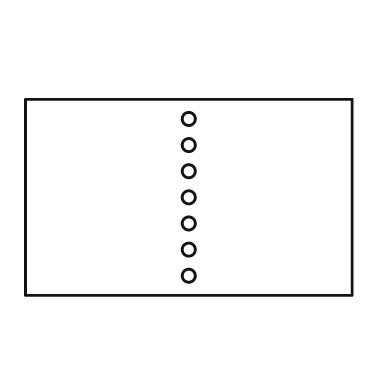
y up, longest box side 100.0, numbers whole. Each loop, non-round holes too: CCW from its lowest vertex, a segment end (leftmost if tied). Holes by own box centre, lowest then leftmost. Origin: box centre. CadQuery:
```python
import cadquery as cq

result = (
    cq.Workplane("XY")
    .moveTo(-50.0, -30.0)
    .lineTo(50.0, -30.0)
    .lineTo(50.0, 30.0)
    .lineTo(-50.0, 30.0)
    .close()
    .moveTo(0.0, -24.0)
    .circle(2.0)
    .moveTo(0.0, -16.0)
    .circle(2.0)
    .moveTo(0.0, -8.0)
    .circle(2.0)
    .moveTo(0.0, 0.0)
    .circle(2.0)
    .moveTo(0.0, 8.0)
    .circle(2.0)
    .moveTo(0.0, 16.0)
    .circle(2.0)
    .moveTo(0.0, 24.0)
    .circle(2.0)
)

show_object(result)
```